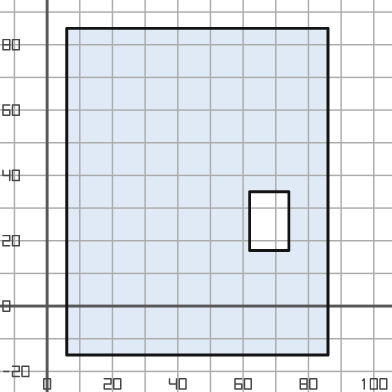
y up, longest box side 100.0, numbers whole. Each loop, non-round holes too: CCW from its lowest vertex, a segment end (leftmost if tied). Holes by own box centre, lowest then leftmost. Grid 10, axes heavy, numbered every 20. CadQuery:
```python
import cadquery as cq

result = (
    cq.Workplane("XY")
    .moveTo(6.0, -15.0)
    .lineTo(86.0, -15.0)
    .lineTo(86.0, 85.0)
    .lineTo(6.0, 85.0)
    .close()
    .moveTo(62.0, 17.0)
    .lineTo(74.0, 17.0)
    .lineTo(74.0, 35.0)
    .lineTo(62.0, 35.0)
    .close()
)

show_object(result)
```